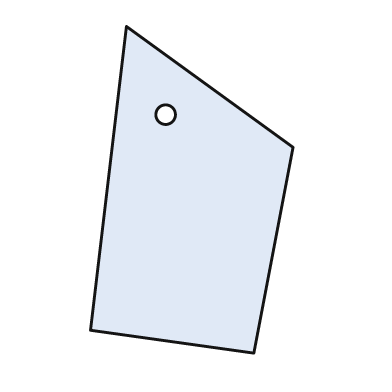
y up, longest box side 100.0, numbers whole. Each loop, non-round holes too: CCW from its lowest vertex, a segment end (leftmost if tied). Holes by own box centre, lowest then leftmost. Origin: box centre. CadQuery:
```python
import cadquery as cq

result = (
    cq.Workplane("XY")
    .moveTo(19.0, -50.0)
    .lineTo(31.0, 13.0)
    .lineTo(-20.0, 50.0)
    .lineTo(-31.0, -43.0)
    .close()
    .moveTo(-8.0, 23.0)
    .circle(3.0)
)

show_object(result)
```